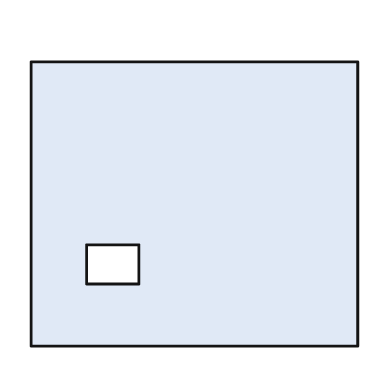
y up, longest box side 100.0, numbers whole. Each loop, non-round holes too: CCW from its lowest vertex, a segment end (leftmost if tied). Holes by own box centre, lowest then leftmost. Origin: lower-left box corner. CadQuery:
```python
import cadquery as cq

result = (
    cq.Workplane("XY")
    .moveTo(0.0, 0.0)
    .lineTo(100.0, 0.0)
    .lineTo(100.0, 87.0)
    .lineTo(0.0, 87.0)
    .close()
    .moveTo(17.0, 19.0)
    .lineTo(33.0, 19.0)
    .lineTo(33.0, 31.0)
    .lineTo(17.0, 31.0)
    .close()
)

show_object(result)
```